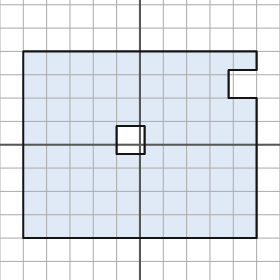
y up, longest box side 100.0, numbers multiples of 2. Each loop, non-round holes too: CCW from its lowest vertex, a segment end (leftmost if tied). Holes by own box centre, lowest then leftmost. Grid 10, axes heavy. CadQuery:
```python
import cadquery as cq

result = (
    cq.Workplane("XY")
    .moveTo(-50.0, -40.0)
    .lineTo(50.0, -40.0)
    .lineTo(50.0, 20.0)
    .lineTo(38.0, 20.0)
    .lineTo(38.0, 32.0)
    .lineTo(50.0, 32.0)
    .lineTo(50.0, 40.0)
    .lineTo(-50.0, 40.0)
    .close()
    .moveTo(-10.0, -4.0)
    .lineTo(2.0, -4.0)
    .lineTo(2.0, 8.0)
    .lineTo(-10.0, 8.0)
    .close()
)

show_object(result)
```